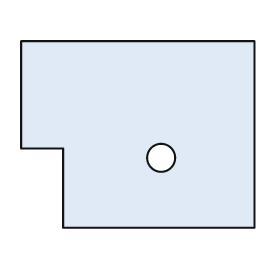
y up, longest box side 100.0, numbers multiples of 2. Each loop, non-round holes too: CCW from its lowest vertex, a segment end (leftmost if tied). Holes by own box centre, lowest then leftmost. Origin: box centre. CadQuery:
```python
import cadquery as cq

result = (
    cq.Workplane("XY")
    .moveTo(-32.0, -40.0)
    .lineTo(50.0, -40.0)
    .lineTo(50.0, 40.0)
    .lineTo(-50.0, 40.0)
    .lineTo(-50.0, -6.0)
    .lineTo(-32.0, -6.0)
    .close()
    .moveTo(10.0, -10.0)
    .circle(6.0)
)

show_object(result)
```